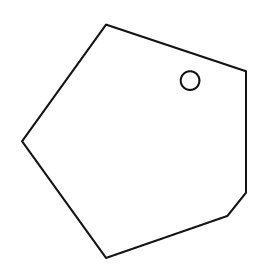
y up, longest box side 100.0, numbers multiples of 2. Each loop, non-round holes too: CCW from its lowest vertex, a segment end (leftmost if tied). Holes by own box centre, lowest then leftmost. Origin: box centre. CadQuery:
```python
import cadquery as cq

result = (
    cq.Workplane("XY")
    .moveTo(-12.0, -50.0)
    .lineTo(40.0, -32.0)
    .lineTo(48.0, -22.0)
    .lineTo(48.0, 30.0)
    .lineTo(-12.0, 50.0)
    .lineTo(-48.0, 0.0)
    .close()
    .moveTo(24.0, 26.0)
    .circle(4.0)
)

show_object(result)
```